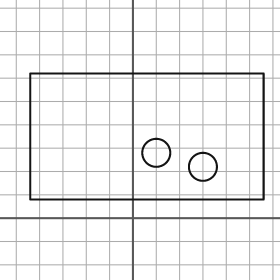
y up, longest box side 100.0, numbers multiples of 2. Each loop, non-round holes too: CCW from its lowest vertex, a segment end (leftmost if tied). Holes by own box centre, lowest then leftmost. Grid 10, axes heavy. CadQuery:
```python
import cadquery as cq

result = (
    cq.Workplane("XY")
    .moveTo(-44.0, 8.0)
    .lineTo(56.0, 8.0)
    .lineTo(56.0, 62.0)
    .lineTo(-44.0, 62.0)
    .close()
    .moveTo(30.0, 22.0)
    .circle(6.0)
    .moveTo(10.0, 28.0)
    .circle(6.0)
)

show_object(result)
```